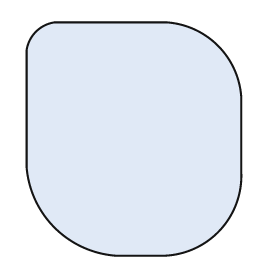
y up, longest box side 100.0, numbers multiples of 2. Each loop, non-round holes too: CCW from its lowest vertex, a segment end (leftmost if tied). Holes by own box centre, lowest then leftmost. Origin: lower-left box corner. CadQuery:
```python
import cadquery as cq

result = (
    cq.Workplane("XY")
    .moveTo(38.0, 0.0)
    .lineTo(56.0, 0.0)
    .threePointArc((82.0, 10.0), (92.0, 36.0))
    .lineTo(92.0, 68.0)
    .threePointArc((82.0, 90.0), (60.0, 100.0))
    .lineTo(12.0, 100.0)
    .threePointArc((4.0, 96.0), (0.0, 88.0))
    .lineTo(0.0, 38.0)
    .threePointArc((12.0, 12.0), (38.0, 0.0))
    .close()
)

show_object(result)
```